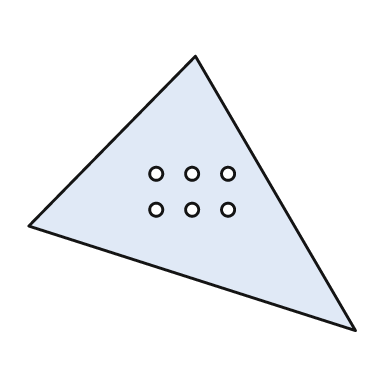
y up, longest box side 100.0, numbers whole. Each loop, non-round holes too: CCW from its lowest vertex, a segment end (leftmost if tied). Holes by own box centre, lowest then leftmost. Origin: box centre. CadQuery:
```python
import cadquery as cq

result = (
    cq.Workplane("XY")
    .moveTo(50.0, -42.0)
    .lineTo(1.0, 42.0)
    .lineTo(-50.0, -10.0)
    .close()
    .moveTo(-11.0, -5.0)
    .circle(2.0)
    .moveTo(0.0, -5.0)
    .circle(2.0)
    .moveTo(11.0, -5.0)
    .circle(2.0)
    .moveTo(-11.0, 6.0)
    .circle(2.0)
    .moveTo(0.0, 6.0)
    .circle(2.0)
    .moveTo(11.0, 6.0)
    .circle(2.0)
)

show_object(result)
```